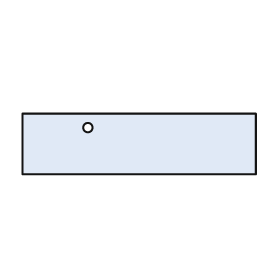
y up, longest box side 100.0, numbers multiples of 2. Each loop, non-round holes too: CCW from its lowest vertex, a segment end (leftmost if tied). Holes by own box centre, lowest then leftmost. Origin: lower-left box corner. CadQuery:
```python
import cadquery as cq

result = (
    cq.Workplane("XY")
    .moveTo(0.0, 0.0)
    .lineTo(100.0, 0.0)
    .lineTo(100.0, 26.0)
    .lineTo(0.0, 26.0)
    .close()
    .moveTo(28.0, 20.0)
    .circle(2.0)
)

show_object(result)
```